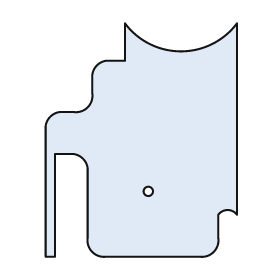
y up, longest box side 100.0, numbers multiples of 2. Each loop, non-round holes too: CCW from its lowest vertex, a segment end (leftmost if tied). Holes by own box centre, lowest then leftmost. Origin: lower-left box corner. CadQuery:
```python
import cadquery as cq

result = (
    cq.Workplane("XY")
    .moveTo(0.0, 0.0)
    .lineTo(4.0, 0.0)
    .lineTo(4.0, 44.0)
    .lineTo(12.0, 44.0)
    .threePointArc((16.0, 42.0), (18.0, 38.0))
    .lineTo(18.0, 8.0)
    .threePointArc((20.0, 2.0), (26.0, 0.0))
    .lineTo(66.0, 0.0)
    .threePointArc((72.0, 2.0), (74.0, 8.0))
    .lineTo(74.0, 18.0)
    .threePointArc((78.0, 20.0), (82.0, 18.0))
    .lineTo(82.0, 100.0)
    .threePointArc((58.0, 88.0), (34.0, 100.0))
    .lineTo(34.0, 84.0)
    .lineTo(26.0, 84.0)
    .threePointArc((22.0, 82.0), (20.0, 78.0))
    .lineTo(20.0, 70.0)
    .threePointArc((18.0, 64.0), (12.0, 62.0))
    .lineTo(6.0, 62.0)
    .threePointArc((2.0, 60.0), (0.0, 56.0))
    .close()
    .moveTo(44.0, 28.0)
    .circle(2.0)
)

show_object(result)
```